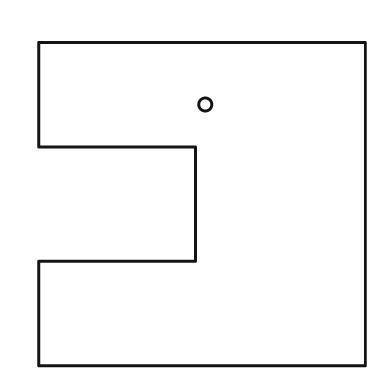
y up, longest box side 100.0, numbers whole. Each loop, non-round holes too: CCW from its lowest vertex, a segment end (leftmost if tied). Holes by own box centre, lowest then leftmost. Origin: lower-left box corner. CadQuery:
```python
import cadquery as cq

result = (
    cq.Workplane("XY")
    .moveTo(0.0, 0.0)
    .lineTo(100.0, 0.0)
    .lineTo(100.0, 99.0)
    .lineTo(0.0, 99.0)
    .lineTo(0.0, 67.0)
    .lineTo(48.0, 67.0)
    .lineTo(48.0, 32.0)
    .lineTo(0.0, 32.0)
    .close()
    .moveTo(51.0, 80.0)
    .circle(2.0)
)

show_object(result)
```